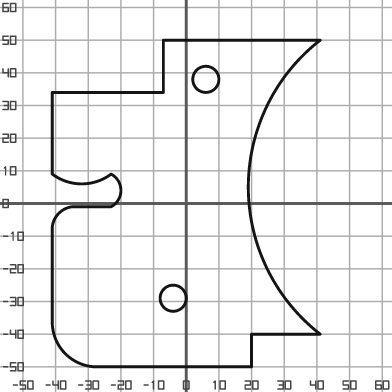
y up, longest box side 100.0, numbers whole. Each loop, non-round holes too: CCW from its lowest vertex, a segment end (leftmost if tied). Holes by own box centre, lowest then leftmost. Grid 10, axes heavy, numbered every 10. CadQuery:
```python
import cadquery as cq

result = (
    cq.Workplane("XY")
    .moveTo(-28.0, -50.0)
    .lineTo(20.0, -50.0)
    .lineTo(20.0, -40.0)
    .lineTo(41.0, -40.0)
    .threePointArc((19.0, 5.0), (41.0, 50.0))
    .lineTo(-7.0, 50.0)
    .lineTo(-7.0, 34.0)
    .lineTo(-41.0, 34.0)
    .lineTo(-41.0, 9.0)
    .threePointArc((-32.0, 6.0), (-23.0, 9.0))
    .threePointArc((-20.0, 4.0), (-23.0, -1.0))
    .lineTo(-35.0, -1.0)
    .threePointArc((-39.0, -3.0), (-41.0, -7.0))
    .lineTo(-41.0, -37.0)
    .threePointArc((-37.0, -46.0), (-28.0, -50.0))
    .close()
    .moveTo(-4.0, -29.0)
    .circle(4.0)
    .moveTo(6.0, 38.0)
    .circle(4.0)
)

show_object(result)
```